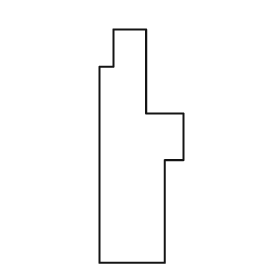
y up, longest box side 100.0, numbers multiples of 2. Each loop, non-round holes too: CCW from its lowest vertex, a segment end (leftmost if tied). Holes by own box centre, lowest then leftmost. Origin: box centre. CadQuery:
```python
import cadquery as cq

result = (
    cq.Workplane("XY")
    .moveTo(-18.0, -50.0)
    .lineTo(10.0, -50.0)
    .lineTo(10.0, -6.0)
    .lineTo(18.0, -6.0)
    .lineTo(18.0, 14.0)
    .lineTo(2.0, 14.0)
    .lineTo(2.0, 50.0)
    .lineTo(-12.0, 50.0)
    .lineTo(-12.0, 34.0)
    .lineTo(-18.0, 34.0)
    .close()
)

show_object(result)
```